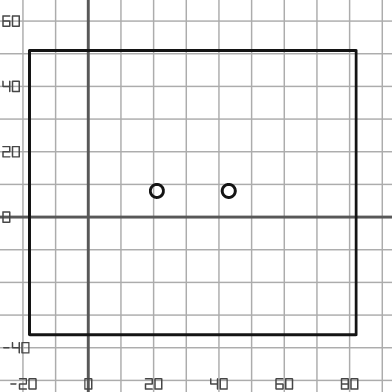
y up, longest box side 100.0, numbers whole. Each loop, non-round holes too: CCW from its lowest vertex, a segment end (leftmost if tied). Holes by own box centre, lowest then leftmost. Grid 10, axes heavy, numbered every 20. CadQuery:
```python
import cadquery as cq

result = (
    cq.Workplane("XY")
    .moveTo(-18.0, -36.0)
    .lineTo(82.0, -36.0)
    .lineTo(82.0, 51.0)
    .lineTo(-18.0, 51.0)
    .close()
    .moveTo(21.0, 8.0)
    .circle(2.0)
    .moveTo(43.0, 8.0)
    .circle(2.0)
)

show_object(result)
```